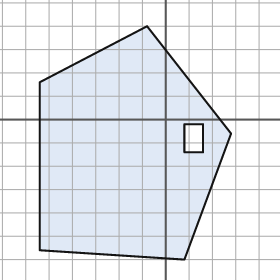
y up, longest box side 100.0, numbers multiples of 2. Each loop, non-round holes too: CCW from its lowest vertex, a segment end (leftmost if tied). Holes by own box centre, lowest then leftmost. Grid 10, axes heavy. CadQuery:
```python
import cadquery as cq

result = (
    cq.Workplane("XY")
    .moveTo(8.0, -60.0)
    .lineTo(28.0, -6.0)
    .lineTo(-8.0, 40.0)
    .lineTo(-54.0, 16.0)
    .lineTo(-54.0, -56.0)
    .close()
    .moveTo(8.0, -14.0)
    .lineTo(16.0, -14.0)
    .lineTo(16.0, -2.0)
    .lineTo(8.0, -2.0)
    .close()
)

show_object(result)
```